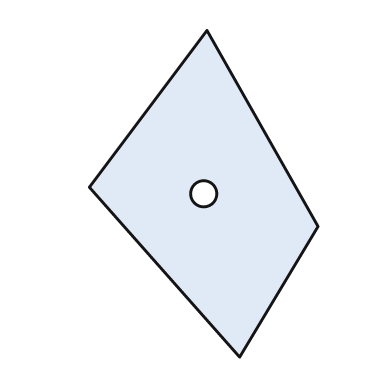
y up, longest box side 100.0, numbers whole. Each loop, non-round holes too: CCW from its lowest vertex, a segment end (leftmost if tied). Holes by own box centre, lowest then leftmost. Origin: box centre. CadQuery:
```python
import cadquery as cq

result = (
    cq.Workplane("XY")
    .moveTo(11.0, -50.0)
    .lineTo(35.0, -10.0)
    .lineTo(1.0, 50.0)
    .lineTo(-35.0, 2.0)
    .close()
    .moveTo(0.0, 0.0)
    .circle(4.0)
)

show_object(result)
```